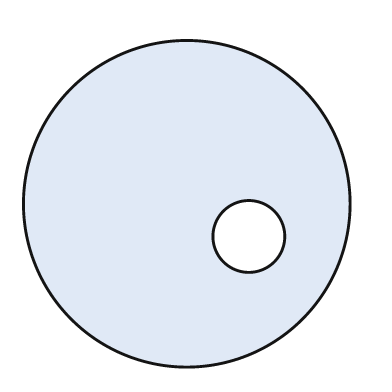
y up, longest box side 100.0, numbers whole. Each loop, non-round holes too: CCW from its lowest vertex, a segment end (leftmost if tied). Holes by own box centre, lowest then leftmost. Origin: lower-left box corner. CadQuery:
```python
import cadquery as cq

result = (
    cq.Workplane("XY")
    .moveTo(50.0, 50.0)
    .circle(50.0)
    .moveTo(69.0, 40.0)
    .circle(11.0)
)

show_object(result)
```